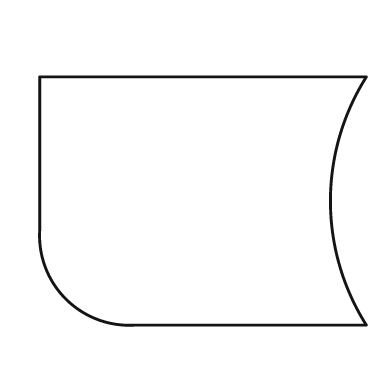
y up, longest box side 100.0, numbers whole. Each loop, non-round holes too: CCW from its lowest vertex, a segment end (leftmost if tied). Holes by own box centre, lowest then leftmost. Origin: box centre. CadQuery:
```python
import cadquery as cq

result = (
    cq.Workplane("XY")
    .moveTo(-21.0, -38.0)
    .lineTo(50.0, -38.0)
    .threePointArc((39.0, 0.0), (50.0, 38.0))
    .lineTo(-50.0, 38.0)
    .lineTo(-50.0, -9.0)
    .threePointArc((-42.0, -30.0), (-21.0, -38.0))
    .close()
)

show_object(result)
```